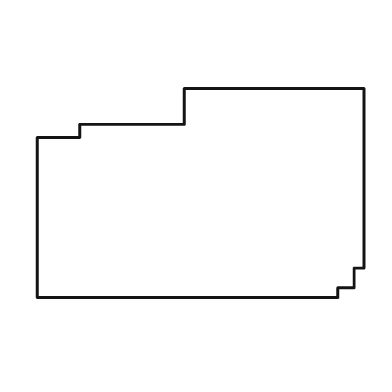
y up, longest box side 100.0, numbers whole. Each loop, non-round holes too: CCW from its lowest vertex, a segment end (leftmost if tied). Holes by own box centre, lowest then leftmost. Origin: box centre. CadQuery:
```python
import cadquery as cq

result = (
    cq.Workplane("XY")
    .moveTo(-50.0, -32.0)
    .lineTo(42.0, -32.0)
    .lineTo(42.0, -29.0)
    .lineTo(47.0, -29.0)
    .lineTo(47.0, -23.0)
    .lineTo(50.0, -23.0)
    .lineTo(50.0, 32.0)
    .lineTo(-5.0, 32.0)
    .lineTo(-5.0, 21.0)
    .lineTo(-37.0, 21.0)
    .lineTo(-37.0, 17.0)
    .lineTo(-50.0, 17.0)
    .close()
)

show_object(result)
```